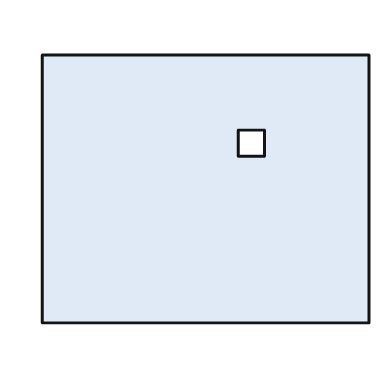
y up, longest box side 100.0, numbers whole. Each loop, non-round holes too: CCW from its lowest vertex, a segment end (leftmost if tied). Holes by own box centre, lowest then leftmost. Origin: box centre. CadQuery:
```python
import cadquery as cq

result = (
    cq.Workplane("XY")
    .moveTo(-50.0, -41.0)
    .lineTo(50.0, -41.0)
    .lineTo(50.0, 41.0)
    .lineTo(-50.0, 41.0)
    .close()
    .moveTo(10.0, 10.0)
    .lineTo(18.0, 10.0)
    .lineTo(18.0, 18.0)
    .lineTo(10.0, 18.0)
    .close()
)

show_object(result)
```